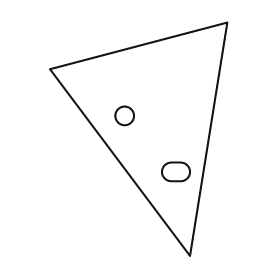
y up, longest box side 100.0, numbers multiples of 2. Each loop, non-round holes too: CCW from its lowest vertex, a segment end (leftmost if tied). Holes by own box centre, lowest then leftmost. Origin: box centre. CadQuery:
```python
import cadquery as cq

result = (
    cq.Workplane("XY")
    .moveTo(22.0, -50.0)
    .lineTo(38.0, 50.0)
    .lineTo(-38.0, 30.0)
    .close()
    .moveTo(14.0, -18.0)
    .lineTo(18.0, -18.0)
    .threePointArc((22.0, -14.0), (18.0, -10.0))
    .lineTo(14.0, -10.0)
    .threePointArc((10.0, -14.0), (14.0, -18.0))
    .close()
    .moveTo(-6.0, 10.0)
    .circle(4.0)
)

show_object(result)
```